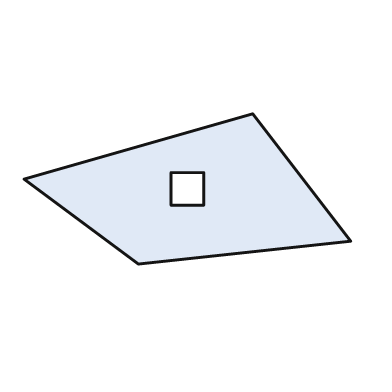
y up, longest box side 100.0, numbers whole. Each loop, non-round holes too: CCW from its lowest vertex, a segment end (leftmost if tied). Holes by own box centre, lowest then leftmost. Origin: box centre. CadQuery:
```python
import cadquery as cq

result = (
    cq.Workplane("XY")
    .moveTo(-15.0, -23.0)
    .lineTo(50.0, -16.0)
    .lineTo(20.0, 23.0)
    .lineTo(-50.0, 3.0)
    .close()
    .moveTo(-5.0, -5.0)
    .lineTo(5.0, -5.0)
    .lineTo(5.0, 5.0)
    .lineTo(-5.0, 5.0)
    .close()
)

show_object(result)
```